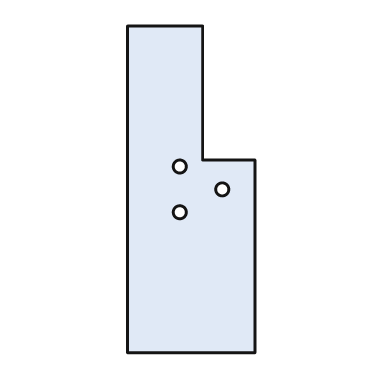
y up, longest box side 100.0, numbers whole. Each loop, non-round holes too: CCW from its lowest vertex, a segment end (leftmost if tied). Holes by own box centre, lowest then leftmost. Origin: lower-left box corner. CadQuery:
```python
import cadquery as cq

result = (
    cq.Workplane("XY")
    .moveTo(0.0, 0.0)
    .lineTo(39.0, 0.0)
    .lineTo(39.0, 59.0)
    .lineTo(23.0, 59.0)
    .lineTo(23.0, 100.0)
    .lineTo(0.0, 100.0)
    .close()
    .moveTo(16.0, 43.0)
    .circle(2.0)
    .moveTo(29.0, 50.0)
    .circle(2.0)
    .moveTo(16.0, 57.0)
    .circle(2.0)
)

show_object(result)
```